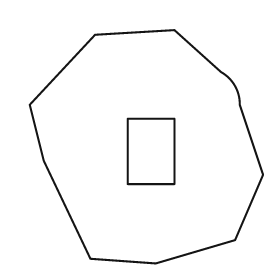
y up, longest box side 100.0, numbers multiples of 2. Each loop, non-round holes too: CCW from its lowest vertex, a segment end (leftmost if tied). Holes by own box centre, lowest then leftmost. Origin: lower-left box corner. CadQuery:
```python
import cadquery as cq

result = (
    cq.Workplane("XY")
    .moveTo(54.0, 0.0)
    .lineTo(88.0, 10.0)
    .lineTo(100.0, 38.0)
    .lineTo(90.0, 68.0)
    .threePointArc((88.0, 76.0), (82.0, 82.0))
    .lineTo(62.0, 100.0)
    .lineTo(28.0, 98.0)
    .lineTo(0.0, 68.0)
    .lineTo(6.0, 44.0)
    .lineTo(26.0, 2.0)
    .close()
    .moveTo(42.0, 34.0)
    .lineTo(62.0, 34.0)
    .lineTo(62.0, 62.0)
    .lineTo(42.0, 62.0)
    .close()
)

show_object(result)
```